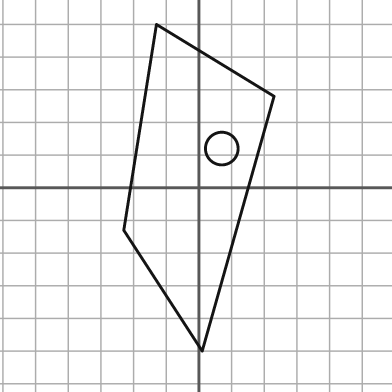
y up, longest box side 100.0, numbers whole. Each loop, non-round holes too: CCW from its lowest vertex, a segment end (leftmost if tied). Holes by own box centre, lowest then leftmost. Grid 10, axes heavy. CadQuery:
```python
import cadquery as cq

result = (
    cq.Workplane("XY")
    .moveTo(1.0, -50.0)
    .lineTo(23.0, 28.0)
    .lineTo(-13.0, 50.0)
    .lineTo(-23.0, -13.0)
    .close()
    .moveTo(7.0, 12.0)
    .circle(5.0)
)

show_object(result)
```